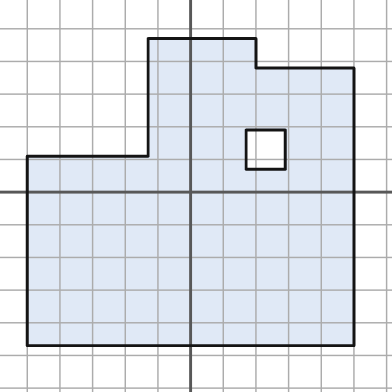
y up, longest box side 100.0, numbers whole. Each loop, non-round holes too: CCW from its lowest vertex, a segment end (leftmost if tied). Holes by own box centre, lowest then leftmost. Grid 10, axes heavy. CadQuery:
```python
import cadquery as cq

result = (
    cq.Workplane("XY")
    .moveTo(-50.0, -47.0)
    .lineTo(50.0, -47.0)
    .lineTo(50.0, 38.0)
    .lineTo(20.0, 38.0)
    .lineTo(20.0, 47.0)
    .lineTo(-13.0, 47.0)
    .lineTo(-13.0, 11.0)
    .lineTo(-50.0, 11.0)
    .close()
    .moveTo(17.0, 7.0)
    .lineTo(29.0, 7.0)
    .lineTo(29.0, 19.0)
    .lineTo(17.0, 19.0)
    .close()
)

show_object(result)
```